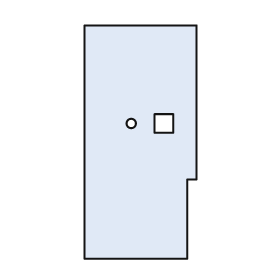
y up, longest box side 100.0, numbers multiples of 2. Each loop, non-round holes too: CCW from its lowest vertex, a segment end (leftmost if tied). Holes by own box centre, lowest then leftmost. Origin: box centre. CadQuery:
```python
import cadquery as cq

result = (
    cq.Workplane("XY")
    .moveTo(-24.0, -50.0)
    .lineTo(20.0, -50.0)
    .lineTo(20.0, -16.0)
    .lineTo(24.0, -16.0)
    .lineTo(24.0, 50.0)
    .lineTo(-24.0, 50.0)
    .close()
    .moveTo(-4.0, 8.0)
    .circle(2.0)
    .moveTo(6.0, 4.0)
    .lineTo(14.0, 4.0)
    .lineTo(14.0, 12.0)
    .lineTo(6.0, 12.0)
    .close()
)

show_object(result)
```